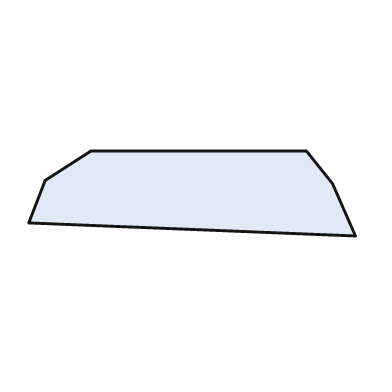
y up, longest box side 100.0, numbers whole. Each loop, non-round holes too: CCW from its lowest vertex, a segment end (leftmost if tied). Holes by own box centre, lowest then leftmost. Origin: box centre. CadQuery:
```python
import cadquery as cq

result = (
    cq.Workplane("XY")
    .moveTo(50.0, -13.0)
    .lineTo(43.0, 3.0)
    .lineTo(35.0, 13.0)
    .lineTo(-31.0, 13.0)
    .lineTo(-45.0, 4.0)
    .lineTo(-50.0, -9.0)
    .close()
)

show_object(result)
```